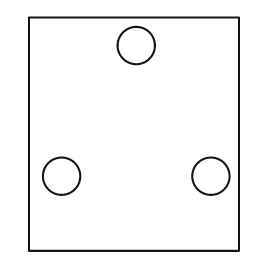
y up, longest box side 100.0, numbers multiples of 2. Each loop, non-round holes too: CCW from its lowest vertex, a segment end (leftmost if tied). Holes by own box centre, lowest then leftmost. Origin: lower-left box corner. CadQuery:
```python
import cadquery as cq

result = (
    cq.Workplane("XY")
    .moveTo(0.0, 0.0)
    .lineTo(90.0, 0.0)
    .lineTo(90.0, 100.0)
    .lineTo(0.0, 100.0)
    .close()
    .moveTo(14.0, 32.0)
    .circle(8.0)
    .moveTo(78.0, 32.0)
    .circle(8.0)
    .moveTo(46.0, 88.0)
    .circle(8.0)
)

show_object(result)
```